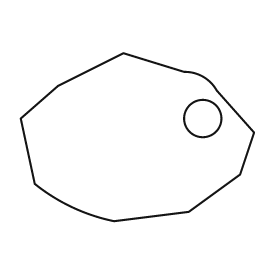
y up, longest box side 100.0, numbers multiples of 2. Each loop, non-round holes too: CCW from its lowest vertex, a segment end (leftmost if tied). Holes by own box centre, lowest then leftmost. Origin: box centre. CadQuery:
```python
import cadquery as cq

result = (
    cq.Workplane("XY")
    .moveTo(-10.0, -36.0)
    .lineTo(22.0, -32.0)
    .lineTo(44.0, -16.0)
    .lineTo(50.0, 2.0)
    .lineTo(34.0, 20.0)
    .threePointArc((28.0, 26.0), (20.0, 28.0))
    .lineTo(-6.0, 36.0)
    .lineTo(-34.0, 22.0)
    .lineTo(-50.0, 8.0)
    .lineTo(-44.0, -20.0)
    .threePointArc((-28.0, -30.0), (-10.0, -36.0))
    .close()
    .moveTo(28.0, 8.0)
    .circle(8.0)
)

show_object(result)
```